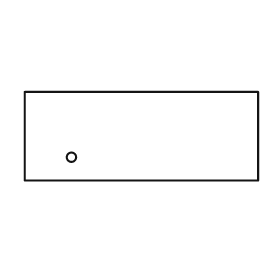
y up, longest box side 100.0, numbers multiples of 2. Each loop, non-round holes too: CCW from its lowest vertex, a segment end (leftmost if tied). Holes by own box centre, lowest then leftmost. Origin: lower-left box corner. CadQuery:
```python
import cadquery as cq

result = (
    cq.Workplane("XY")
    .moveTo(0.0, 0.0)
    .lineTo(100.0, 0.0)
    .lineTo(100.0, 38.0)
    .lineTo(0.0, 38.0)
    .close()
    .moveTo(20.0, 10.0)
    .circle(2.0)
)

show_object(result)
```